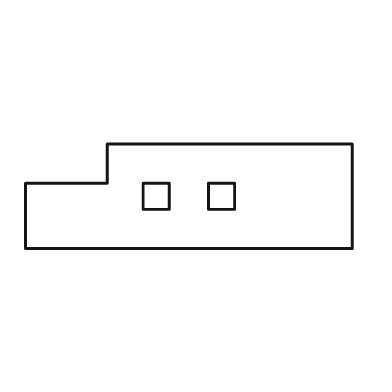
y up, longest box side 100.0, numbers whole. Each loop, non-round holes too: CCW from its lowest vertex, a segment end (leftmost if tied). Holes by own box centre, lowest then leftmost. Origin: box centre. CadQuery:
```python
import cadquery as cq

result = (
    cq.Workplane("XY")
    .moveTo(-50.0, -16.0)
    .lineTo(50.0, -16.0)
    .lineTo(50.0, 16.0)
    .lineTo(-25.0, 16.0)
    .lineTo(-25.0, 4.0)
    .lineTo(-50.0, 4.0)
    .close()
    .moveTo(-14.0, -4.0)
    .lineTo(-6.0, -4.0)
    .lineTo(-6.0, 4.0)
    .lineTo(-14.0, 4.0)
    .close()
    .moveTo(6.0, -4.0)
    .lineTo(14.0, -4.0)
    .lineTo(14.0, 4.0)
    .lineTo(6.0, 4.0)
    .close()
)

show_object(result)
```